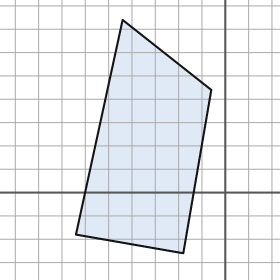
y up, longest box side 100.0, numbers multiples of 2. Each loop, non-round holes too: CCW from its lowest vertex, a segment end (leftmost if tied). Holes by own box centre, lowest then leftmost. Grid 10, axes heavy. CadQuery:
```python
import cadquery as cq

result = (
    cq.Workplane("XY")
    .moveTo(-18.0, -26.0)
    .lineTo(-6.0, 44.0)
    .lineTo(-44.0, 74.0)
    .lineTo(-64.0, -18.0)
    .close()
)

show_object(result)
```